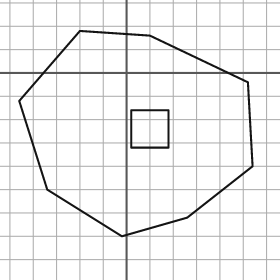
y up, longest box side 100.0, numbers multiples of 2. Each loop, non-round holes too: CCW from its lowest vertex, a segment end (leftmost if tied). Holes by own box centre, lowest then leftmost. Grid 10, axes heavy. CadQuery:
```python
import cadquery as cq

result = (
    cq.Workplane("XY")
    .moveTo(-2.0, -70.0)
    .lineTo(26.0, -62.0)
    .lineTo(54.0, -40.0)
    .lineTo(52.0, -4.0)
    .lineTo(10.0, 16.0)
    .lineTo(-20.0, 18.0)
    .lineTo(-46.0, -12.0)
    .lineTo(-34.0, -50.0)
    .close()
    .moveTo(2.0, -32.0)
    .lineTo(18.0, -32.0)
    .lineTo(18.0, -16.0)
    .lineTo(2.0, -16.0)
    .close()
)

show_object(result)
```